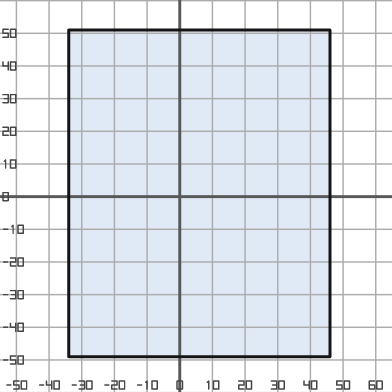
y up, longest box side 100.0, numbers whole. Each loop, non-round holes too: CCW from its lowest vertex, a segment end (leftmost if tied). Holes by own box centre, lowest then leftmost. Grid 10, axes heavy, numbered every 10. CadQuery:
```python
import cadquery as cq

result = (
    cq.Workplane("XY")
    .moveTo(-34.0, -49.0)
    .lineTo(46.0, -49.0)
    .lineTo(46.0, 51.0)
    .lineTo(-34.0, 51.0)
    .close()
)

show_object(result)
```